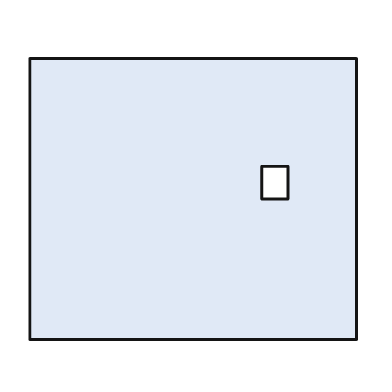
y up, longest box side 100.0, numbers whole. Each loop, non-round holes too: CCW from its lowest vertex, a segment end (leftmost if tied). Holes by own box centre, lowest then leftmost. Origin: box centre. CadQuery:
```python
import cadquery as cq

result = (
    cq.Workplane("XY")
    .moveTo(-50.0, -43.0)
    .lineTo(50.0, -43.0)
    .lineTo(50.0, 43.0)
    .lineTo(-50.0, 43.0)
    .close()
    .moveTo(21.0, 0.0)
    .lineTo(29.0, 0.0)
    .lineTo(29.0, 10.0)
    .lineTo(21.0, 10.0)
    .close()
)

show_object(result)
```